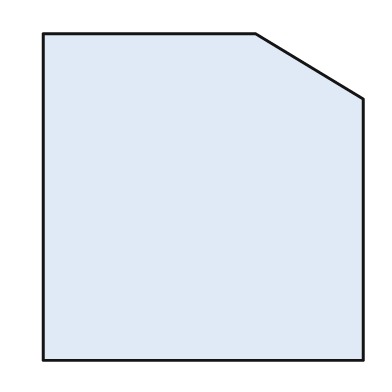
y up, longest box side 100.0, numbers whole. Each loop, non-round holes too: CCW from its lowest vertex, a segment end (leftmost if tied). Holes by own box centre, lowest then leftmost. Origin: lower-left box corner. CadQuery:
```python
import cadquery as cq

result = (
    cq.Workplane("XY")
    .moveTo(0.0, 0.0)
    .lineTo(98.0, 0.0)
    .lineTo(98.0, 80.0)
    .lineTo(65.0, 100.0)
    .lineTo(0.0, 100.0)
    .close()
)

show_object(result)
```